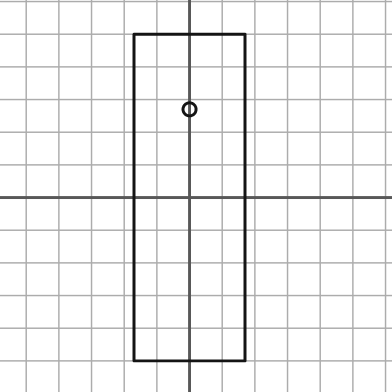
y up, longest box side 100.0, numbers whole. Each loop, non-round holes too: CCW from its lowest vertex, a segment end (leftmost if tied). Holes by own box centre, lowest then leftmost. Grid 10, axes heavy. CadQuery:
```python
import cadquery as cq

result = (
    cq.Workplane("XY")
    .moveTo(-17.0, -50.0)
    .lineTo(17.0, -50.0)
    .lineTo(17.0, 50.0)
    .lineTo(-17.0, 50.0)
    .close()
    .moveTo(0.0, 27.0)
    .circle(2.0)
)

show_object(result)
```